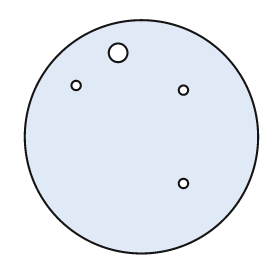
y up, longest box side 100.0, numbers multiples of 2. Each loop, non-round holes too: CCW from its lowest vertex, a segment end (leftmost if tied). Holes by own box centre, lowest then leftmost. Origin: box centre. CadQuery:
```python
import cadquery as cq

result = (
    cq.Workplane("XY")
    .moveTo(0.0, 0.0)
    .circle(50.0)
    .moveTo(18.0, -20.0)
    .circle(2.0)
    .moveTo(18.0, 20.0)
    .circle(2.0)
    .moveTo(-28.0, 22.0)
    .circle(2.0)
    .moveTo(-10.0, 36.0)
    .circle(4.0)
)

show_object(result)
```